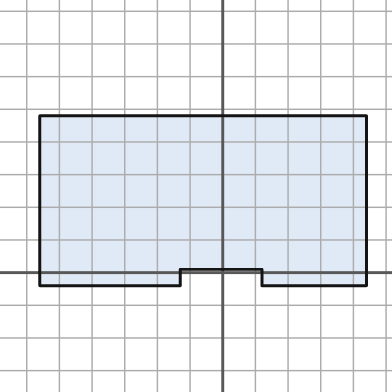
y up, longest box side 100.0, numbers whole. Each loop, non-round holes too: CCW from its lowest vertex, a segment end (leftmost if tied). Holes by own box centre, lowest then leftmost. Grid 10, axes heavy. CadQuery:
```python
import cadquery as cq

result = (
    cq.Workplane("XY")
    .moveTo(-56.0, -4.0)
    .lineTo(-13.0, -4.0)
    .lineTo(-13.0, 1.0)
    .lineTo(12.0, 1.0)
    .lineTo(12.0, -4.0)
    .lineTo(44.0, -4.0)
    .lineTo(44.0, 48.0)
    .lineTo(-56.0, 48.0)
    .close()
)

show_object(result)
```